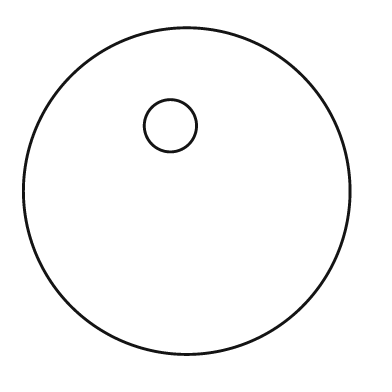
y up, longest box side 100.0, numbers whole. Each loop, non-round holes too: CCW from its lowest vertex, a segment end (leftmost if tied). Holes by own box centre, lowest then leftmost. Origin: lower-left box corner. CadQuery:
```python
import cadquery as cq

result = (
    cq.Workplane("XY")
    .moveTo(50.0, 50.0)
    .circle(50.0)
    .moveTo(45.0, 70.0)
    .circle(8.0)
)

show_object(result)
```